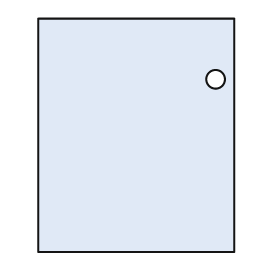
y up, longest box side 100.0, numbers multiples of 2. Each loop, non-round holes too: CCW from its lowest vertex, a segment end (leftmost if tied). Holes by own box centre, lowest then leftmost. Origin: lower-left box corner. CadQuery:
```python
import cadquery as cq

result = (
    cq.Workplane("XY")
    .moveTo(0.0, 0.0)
    .lineTo(84.0, 0.0)
    .lineTo(84.0, 100.0)
    .lineTo(0.0, 100.0)
    .close()
    .moveTo(76.0, 74.0)
    .circle(4.0)
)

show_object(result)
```